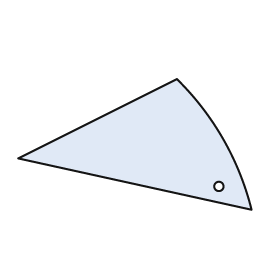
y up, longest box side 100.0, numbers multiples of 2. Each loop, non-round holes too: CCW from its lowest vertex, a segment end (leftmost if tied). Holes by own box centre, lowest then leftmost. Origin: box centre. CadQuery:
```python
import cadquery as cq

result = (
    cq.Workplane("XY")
    .moveTo(50.0, -28.0)
    .threePointArc((38.0, 2.0), (18.0, 28.0))
    .lineTo(-50.0, -6.0)
    .close()
    .moveTo(36.0, -18.0)
    .circle(2.0)
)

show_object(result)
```